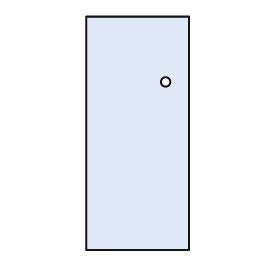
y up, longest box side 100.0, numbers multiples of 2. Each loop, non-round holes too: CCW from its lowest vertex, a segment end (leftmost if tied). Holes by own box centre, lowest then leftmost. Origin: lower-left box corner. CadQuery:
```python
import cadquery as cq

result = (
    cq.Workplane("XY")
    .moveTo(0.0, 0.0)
    .lineTo(44.0, 0.0)
    .lineTo(44.0, 100.0)
    .lineTo(0.0, 100.0)
    .close()
    .moveTo(34.0, 72.0)
    .circle(2.0)
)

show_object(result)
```